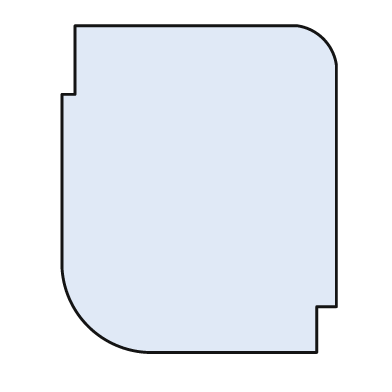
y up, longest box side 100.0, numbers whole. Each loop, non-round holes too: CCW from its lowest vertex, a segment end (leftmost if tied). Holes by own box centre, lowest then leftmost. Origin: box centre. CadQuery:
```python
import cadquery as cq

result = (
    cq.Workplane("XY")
    .moveTo(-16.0, -50.0)
    .lineTo(36.0, -50.0)
    .lineTo(36.0, -36.0)
    .lineTo(42.0, -36.0)
    .lineTo(42.0, 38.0)
    .threePointArc((38.0, 46.0), (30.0, 50.0))
    .lineTo(-38.0, 50.0)
    .lineTo(-38.0, 29.0)
    .lineTo(-42.0, 29.0)
    .lineTo(-42.0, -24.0)
    .threePointArc((-34.0, -42.0), (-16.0, -50.0))
    .close()
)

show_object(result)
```